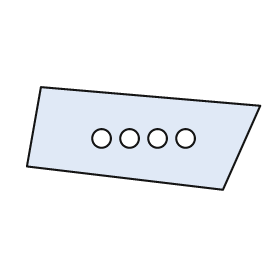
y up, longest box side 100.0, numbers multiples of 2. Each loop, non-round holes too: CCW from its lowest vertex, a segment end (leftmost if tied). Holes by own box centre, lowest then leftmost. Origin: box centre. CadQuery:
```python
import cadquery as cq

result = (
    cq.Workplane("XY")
    .moveTo(34.0, -22.0)
    .lineTo(50.0, 14.0)
    .lineTo(-44.0, 22.0)
    .lineTo(-50.0, -12.0)
    .close()
    .moveTo(-18.0, 0.0)
    .circle(4.0)
    .moveTo(-6.0, 0.0)
    .circle(4.0)
    .moveTo(6.0, 0.0)
    .circle(4.0)
    .moveTo(18.0, 0.0)
    .circle(4.0)
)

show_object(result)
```